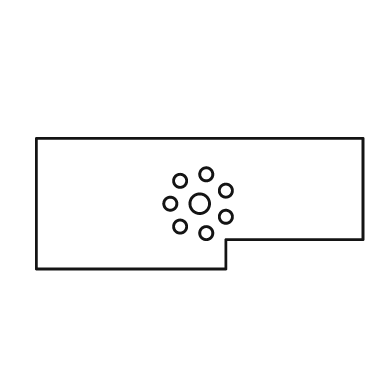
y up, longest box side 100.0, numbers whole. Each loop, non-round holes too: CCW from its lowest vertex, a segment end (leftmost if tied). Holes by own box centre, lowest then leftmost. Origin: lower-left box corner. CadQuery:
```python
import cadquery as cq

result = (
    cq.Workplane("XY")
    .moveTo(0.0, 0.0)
    .lineTo(58.0, 0.0)
    .lineTo(58.0, 9.0)
    .lineTo(100.0, 9.0)
    .lineTo(100.0, 40.0)
    .lineTo(0.0, 40.0)
    .close()
    .moveTo(52.0, 11.0)
    .circle(2.0)
    .moveTo(44.0, 13.0)
    .circle(2.0)
    .moveTo(58.0, 16.0)
    .circle(2.0)
    .moveTo(41.0, 20.0)
    .circle(2.0)
    .moveTo(50.0, 20.0)
    .circle(3.0)
    .moveTo(58.0, 24.0)
    .circle(2.0)
    .moveTo(44.0, 27.0)
    .circle(2.0)
    .moveTo(52.0, 29.0)
    .circle(2.0)
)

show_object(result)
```